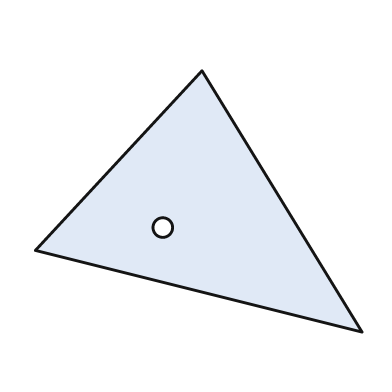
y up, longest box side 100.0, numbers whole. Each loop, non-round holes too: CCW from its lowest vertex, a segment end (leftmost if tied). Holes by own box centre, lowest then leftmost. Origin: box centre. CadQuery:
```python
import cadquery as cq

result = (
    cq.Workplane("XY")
    .moveTo(50.0, -40.0)
    .lineTo(1.0, 40.0)
    .lineTo(-50.0, -15.0)
    .close()
    .moveTo(-11.0, -8.0)
    .circle(3.0)
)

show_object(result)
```